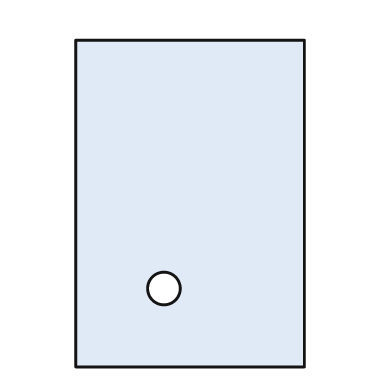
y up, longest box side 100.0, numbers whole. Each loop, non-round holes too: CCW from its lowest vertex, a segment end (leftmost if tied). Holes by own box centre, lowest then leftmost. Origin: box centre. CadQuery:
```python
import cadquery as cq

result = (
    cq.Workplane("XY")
    .moveTo(-35.0, -50.0)
    .lineTo(35.0, -50.0)
    .lineTo(35.0, 50.0)
    .lineTo(-35.0, 50.0)
    .close()
    .moveTo(-8.0, -26.0)
    .circle(5.0)
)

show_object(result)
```